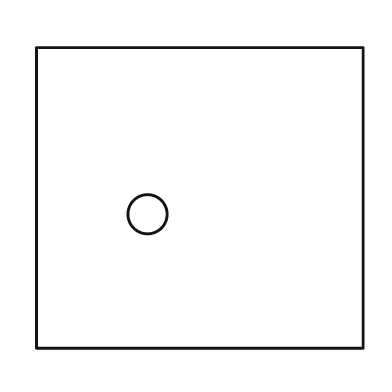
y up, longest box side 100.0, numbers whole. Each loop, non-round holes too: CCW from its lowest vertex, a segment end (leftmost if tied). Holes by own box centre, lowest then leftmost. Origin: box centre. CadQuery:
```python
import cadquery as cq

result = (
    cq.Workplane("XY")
    .moveTo(-50.0, -46.0)
    .lineTo(50.0, -46.0)
    .lineTo(50.0, 46.0)
    .lineTo(-50.0, 46.0)
    .close()
    .moveTo(-16.0, -5.0)
    .circle(6.0)
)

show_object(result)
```